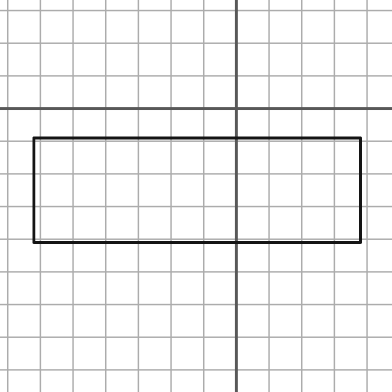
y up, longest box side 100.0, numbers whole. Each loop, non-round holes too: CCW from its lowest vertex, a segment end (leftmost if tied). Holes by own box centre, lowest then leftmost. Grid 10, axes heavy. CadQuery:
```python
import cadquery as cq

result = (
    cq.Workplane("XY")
    .moveTo(-62.0, -41.0)
    .lineTo(38.0, -41.0)
    .lineTo(38.0, -9.0)
    .lineTo(-62.0, -9.0)
    .close()
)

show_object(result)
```